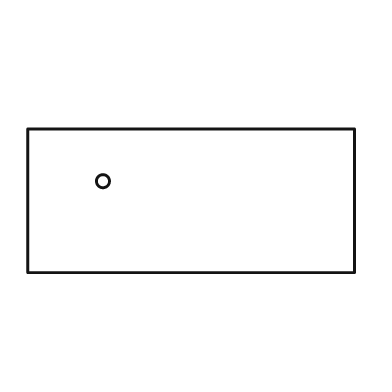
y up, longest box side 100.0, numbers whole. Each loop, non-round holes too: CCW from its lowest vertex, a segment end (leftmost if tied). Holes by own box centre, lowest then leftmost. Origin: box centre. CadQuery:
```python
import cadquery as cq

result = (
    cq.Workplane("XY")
    .moveTo(-50.0, -22.0)
    .lineTo(50.0, -22.0)
    .lineTo(50.0, 22.0)
    .lineTo(-50.0, 22.0)
    .close()
    .moveTo(-27.0, 6.0)
    .circle(2.0)
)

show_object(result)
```